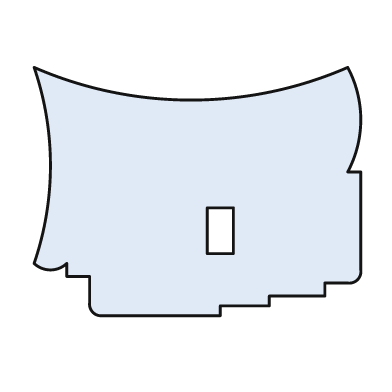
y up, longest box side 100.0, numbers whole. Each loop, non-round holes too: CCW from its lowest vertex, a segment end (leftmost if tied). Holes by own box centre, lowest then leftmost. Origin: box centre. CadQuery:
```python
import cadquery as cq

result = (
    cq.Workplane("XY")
    .moveTo(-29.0, -38.0)
    .lineTo(7.0, -38.0)
    .lineTo(7.0, -35.0)
    .lineTo(22.0, -35.0)
    .lineTo(22.0, -32.0)
    .lineTo(39.0, -32.0)
    .lineTo(39.0, -28.0)
    .lineTo(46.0, -28.0)
    .threePointArc((49.0, -27.0), (50.0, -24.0))
    .lineTo(50.0, 6.0)
    .lineTo(46.0, 6.0)
    .threePointArc((50.0, 22.0), (46.0, 38.0))
    .threePointArc((-2.0, 28.0), (-50.0, 38.0))
    .threePointArc((-45.0, 8.0), (-50.0, -22.0))
    .threePointArc((-45.0, -24.0), (-40.0, -22.0))
    .lineTo(-40.0, -26.0)
    .lineTo(-33.0, -26.0)
    .lineTo(-33.0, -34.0)
    .threePointArc((-32.0, -37.0), (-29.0, -38.0))
    .close()
    .moveTo(3.0, -19.0)
    .lineTo(11.0, -19.0)
    .lineTo(11.0, -5.0)
    .lineTo(3.0, -5.0)
    .close()
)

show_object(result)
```